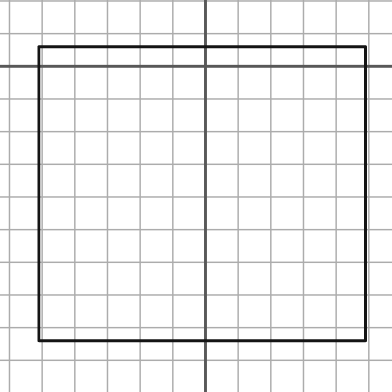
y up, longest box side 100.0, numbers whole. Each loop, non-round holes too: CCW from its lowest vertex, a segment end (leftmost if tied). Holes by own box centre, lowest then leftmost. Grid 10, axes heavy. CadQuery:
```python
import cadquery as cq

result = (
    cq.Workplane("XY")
    .moveTo(-51.0, -84.0)
    .lineTo(49.0, -84.0)
    .lineTo(49.0, 6.0)
    .lineTo(-51.0, 6.0)
    .close()
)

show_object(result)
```